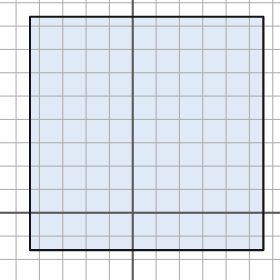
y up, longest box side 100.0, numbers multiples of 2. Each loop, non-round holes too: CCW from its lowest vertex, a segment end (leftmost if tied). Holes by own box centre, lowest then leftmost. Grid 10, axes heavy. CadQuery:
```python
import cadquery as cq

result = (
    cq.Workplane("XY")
    .moveTo(-44.0, -16.0)
    .lineTo(56.0, -16.0)
    .lineTo(56.0, 84.0)
    .lineTo(-44.0, 84.0)
    .close()
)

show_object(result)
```